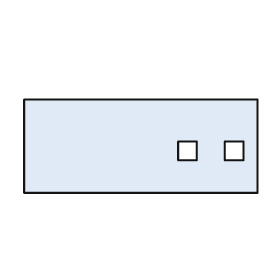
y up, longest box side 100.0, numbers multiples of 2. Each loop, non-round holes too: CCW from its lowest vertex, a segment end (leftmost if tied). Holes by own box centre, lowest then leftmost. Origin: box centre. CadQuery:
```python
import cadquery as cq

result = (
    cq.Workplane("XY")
    .moveTo(-50.0, -20.0)
    .lineTo(50.0, -20.0)
    .lineTo(50.0, 20.0)
    .lineTo(-50.0, 20.0)
    .close()
    .moveTo(16.0, -6.0)
    .lineTo(24.0, -6.0)
    .lineTo(24.0, 2.0)
    .lineTo(16.0, 2.0)
    .close()
    .moveTo(36.0, -6.0)
    .lineTo(44.0, -6.0)
    .lineTo(44.0, 2.0)
    .lineTo(36.0, 2.0)
    .close()
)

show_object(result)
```